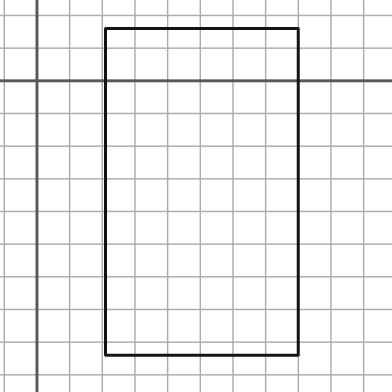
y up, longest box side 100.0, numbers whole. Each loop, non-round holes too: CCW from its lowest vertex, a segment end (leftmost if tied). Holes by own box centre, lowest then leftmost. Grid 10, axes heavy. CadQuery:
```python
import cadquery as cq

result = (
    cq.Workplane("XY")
    .moveTo(21.0, -84.0)
    .lineTo(80.0, -84.0)
    .lineTo(80.0, 16.0)
    .lineTo(21.0, 16.0)
    .close()
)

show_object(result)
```